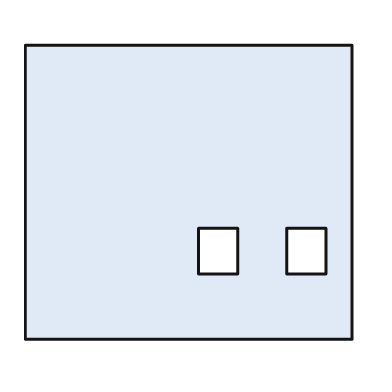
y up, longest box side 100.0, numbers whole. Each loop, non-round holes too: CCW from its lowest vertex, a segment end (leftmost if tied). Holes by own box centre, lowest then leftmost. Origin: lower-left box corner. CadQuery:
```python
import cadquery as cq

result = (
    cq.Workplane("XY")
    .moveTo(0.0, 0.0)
    .lineTo(100.0, 0.0)
    .lineTo(100.0, 90.0)
    .lineTo(0.0, 90.0)
    .close()
    .moveTo(53.0, 20.0)
    .lineTo(65.0, 20.0)
    .lineTo(65.0, 34.0)
    .lineTo(53.0, 34.0)
    .close()
    .moveTo(80.0, 20.0)
    .lineTo(92.0, 20.0)
    .lineTo(92.0, 34.0)
    .lineTo(80.0, 34.0)
    .close()
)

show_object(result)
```